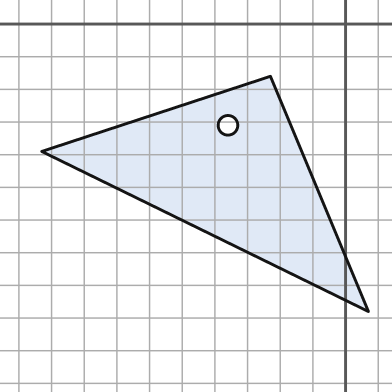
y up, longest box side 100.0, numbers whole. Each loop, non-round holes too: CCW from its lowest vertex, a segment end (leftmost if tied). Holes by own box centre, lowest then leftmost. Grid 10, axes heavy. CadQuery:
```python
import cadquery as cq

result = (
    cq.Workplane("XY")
    .moveTo(7.0, -88.0)
    .lineTo(-23.0, -16.0)
    .lineTo(-93.0, -39.0)
    .close()
    .moveTo(-36.0, -31.0)
    .circle(3.0)
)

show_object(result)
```